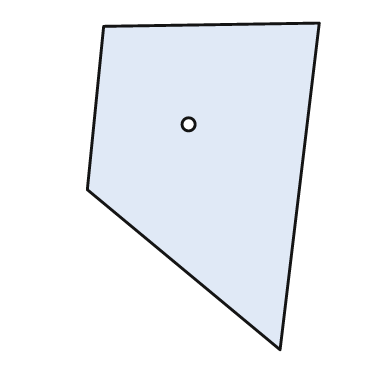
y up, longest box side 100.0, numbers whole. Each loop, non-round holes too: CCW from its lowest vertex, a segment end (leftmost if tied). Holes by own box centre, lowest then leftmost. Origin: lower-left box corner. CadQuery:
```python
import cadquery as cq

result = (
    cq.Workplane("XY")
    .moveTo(59.0, 0.0)
    .lineTo(71.0, 100.0)
    .lineTo(5.0, 99.0)
    .lineTo(0.0, 49.0)
    .close()
    .moveTo(31.0, 69.0)
    .circle(2.0)
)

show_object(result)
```